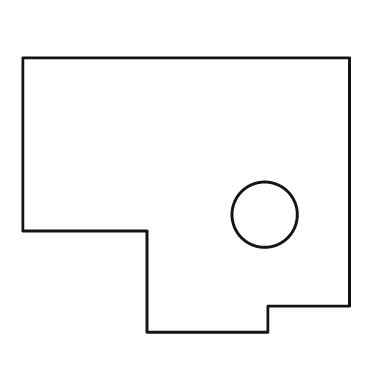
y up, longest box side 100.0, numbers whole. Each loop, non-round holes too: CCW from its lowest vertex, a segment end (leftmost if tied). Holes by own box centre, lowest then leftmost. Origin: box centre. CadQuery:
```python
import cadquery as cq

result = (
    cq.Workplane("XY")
    .moveTo(-12.0, -42.0)
    .lineTo(25.0, -42.0)
    .lineTo(25.0, -34.0)
    .lineTo(50.0, -34.0)
    .lineTo(50.0, 42.0)
    .lineTo(-50.0, 42.0)
    .lineTo(-50.0, -11.0)
    .lineTo(-12.0, -11.0)
    .close()
    .moveTo(24.0, -6.0)
    .circle(10.0)
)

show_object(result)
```